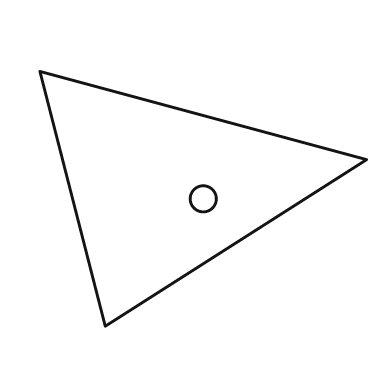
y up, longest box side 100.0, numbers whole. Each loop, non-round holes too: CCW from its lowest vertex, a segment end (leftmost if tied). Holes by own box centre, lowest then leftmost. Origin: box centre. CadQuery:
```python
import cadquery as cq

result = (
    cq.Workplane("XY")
    .moveTo(-30.0, -39.0)
    .lineTo(50.0, 12.0)
    .lineTo(-50.0, 39.0)
    .close()
    .moveTo(0.0, 0.0)
    .circle(4.0)
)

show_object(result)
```